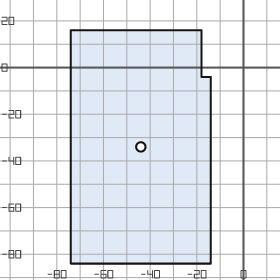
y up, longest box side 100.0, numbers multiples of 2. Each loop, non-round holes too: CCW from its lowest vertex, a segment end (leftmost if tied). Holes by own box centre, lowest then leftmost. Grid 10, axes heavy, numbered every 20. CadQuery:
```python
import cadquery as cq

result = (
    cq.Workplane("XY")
    .moveTo(-74.0, -84.0)
    .lineTo(-14.0, -84.0)
    .lineTo(-14.0, -4.0)
    .lineTo(-18.0, -4.0)
    .lineTo(-18.0, 16.0)
    .lineTo(-74.0, 16.0)
    .close()
    .moveTo(-44.0, -34.0)
    .circle(2.0)
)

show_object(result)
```